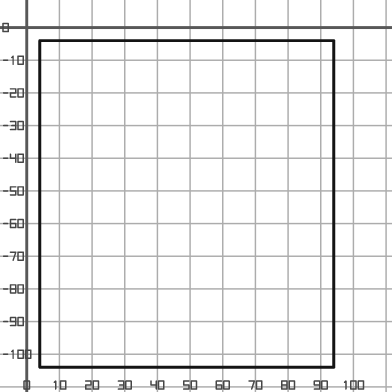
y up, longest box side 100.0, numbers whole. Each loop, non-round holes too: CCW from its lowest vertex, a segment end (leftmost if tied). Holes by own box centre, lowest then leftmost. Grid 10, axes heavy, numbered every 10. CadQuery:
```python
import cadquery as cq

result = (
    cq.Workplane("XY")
    .moveTo(4.0, -104.0)
    .lineTo(94.0, -104.0)
    .lineTo(94.0, -4.0)
    .lineTo(4.0, -4.0)
    .close()
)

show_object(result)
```